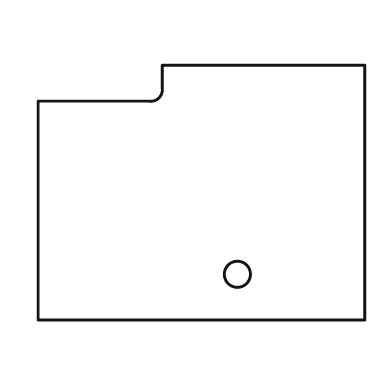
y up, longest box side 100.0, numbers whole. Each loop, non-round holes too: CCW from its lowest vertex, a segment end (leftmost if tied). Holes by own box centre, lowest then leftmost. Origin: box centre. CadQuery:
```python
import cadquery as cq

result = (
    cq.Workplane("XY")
    .moveTo(-50.0, -39.0)
    .lineTo(50.0, -39.0)
    .lineTo(50.0, 39.0)
    .lineTo(-12.0, 39.0)
    .lineTo(-12.0, 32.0)
    .threePointArc((-13.0, 29.0), (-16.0, 28.0))
    .lineTo(-50.0, 28.0)
    .close()
    .moveTo(11.0, -25.0)
    .circle(4.0)
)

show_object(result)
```